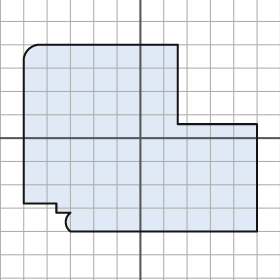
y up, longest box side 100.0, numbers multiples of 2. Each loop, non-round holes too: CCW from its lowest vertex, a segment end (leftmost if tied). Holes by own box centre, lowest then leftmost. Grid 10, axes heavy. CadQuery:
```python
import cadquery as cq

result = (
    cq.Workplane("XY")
    .moveTo(-30.0, -40.0)
    .lineTo(50.0, -40.0)
    .lineTo(50.0, 6.0)
    .lineTo(16.0, 6.0)
    .lineTo(16.0, 40.0)
    .lineTo(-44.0, 40.0)
    .threePointArc((-48.0, 38.0), (-50.0, 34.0))
    .lineTo(-50.0, -28.0)
    .lineTo(-36.0, -28.0)
    .lineTo(-36.0, -32.0)
    .lineTo(-30.0, -32.0)
    .threePointArc((-32.0, -36.0), (-30.0, -40.0))
    .close()
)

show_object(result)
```